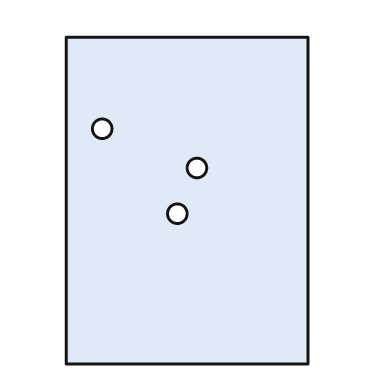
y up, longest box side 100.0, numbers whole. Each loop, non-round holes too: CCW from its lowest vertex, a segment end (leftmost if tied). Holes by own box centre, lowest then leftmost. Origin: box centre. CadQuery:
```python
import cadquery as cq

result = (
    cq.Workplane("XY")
    .moveTo(-37.0, -50.0)
    .lineTo(37.0, -50.0)
    .lineTo(37.0, 50.0)
    .lineTo(-37.0, 50.0)
    .close()
    .moveTo(-3.0, -4.0)
    .circle(3.0)
    .moveTo(3.0, 10.0)
    .circle(3.0)
    .moveTo(-26.0, 22.0)
    .circle(3.0)
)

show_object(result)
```